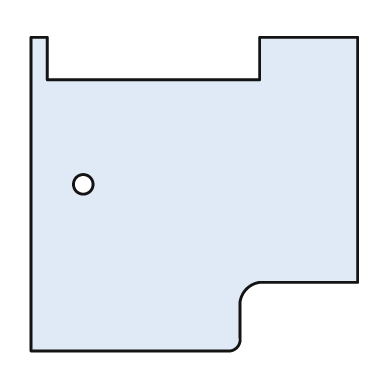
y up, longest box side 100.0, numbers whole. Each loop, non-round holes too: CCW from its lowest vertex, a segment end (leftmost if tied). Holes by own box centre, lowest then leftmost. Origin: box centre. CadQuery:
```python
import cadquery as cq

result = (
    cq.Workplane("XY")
    .moveTo(-50.0, -48.0)
    .lineTo(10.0, -48.0)
    .threePointArc((13.0, -47.0), (14.0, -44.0))
    .lineTo(14.0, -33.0)
    .threePointArc((16.0, -29.0), (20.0, -27.0))
    .lineTo(50.0, -27.0)
    .lineTo(50.0, 48.0)
    .lineTo(20.0, 48.0)
    .lineTo(20.0, 35.0)
    .lineTo(-45.0, 35.0)
    .lineTo(-45.0, 48.0)
    .lineTo(-50.0, 48.0)
    .close()
    .moveTo(-34.0, 3.0)
    .circle(3.0)
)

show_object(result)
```